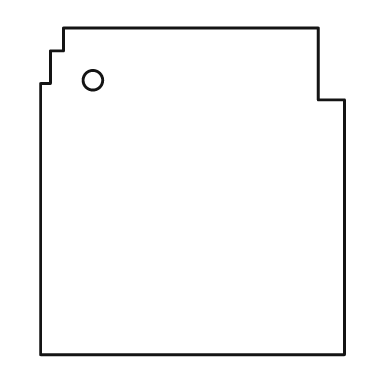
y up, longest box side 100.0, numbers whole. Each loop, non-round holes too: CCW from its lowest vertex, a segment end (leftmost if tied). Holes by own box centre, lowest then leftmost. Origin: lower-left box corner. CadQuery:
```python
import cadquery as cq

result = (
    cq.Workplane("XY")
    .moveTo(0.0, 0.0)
    .lineTo(93.0, 0.0)
    .lineTo(93.0, 78.0)
    .lineTo(85.0, 78.0)
    .lineTo(85.0, 100.0)
    .lineTo(7.0, 100.0)
    .lineTo(7.0, 93.0)
    .lineTo(3.0, 93.0)
    .lineTo(3.0, 83.0)
    .lineTo(0.0, 83.0)
    .close()
    .moveTo(16.0, 84.0)
    .circle(3.0)
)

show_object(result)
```